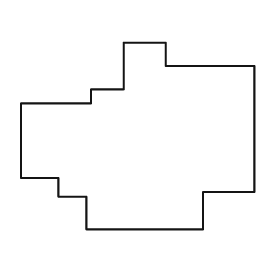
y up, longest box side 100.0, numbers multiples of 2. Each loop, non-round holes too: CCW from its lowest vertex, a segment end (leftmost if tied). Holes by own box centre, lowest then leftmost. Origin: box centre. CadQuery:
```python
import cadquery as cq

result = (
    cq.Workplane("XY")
    .moveTo(-22.0, -40.0)
    .lineTo(28.0, -40.0)
    .lineTo(28.0, -24.0)
    .lineTo(50.0, -24.0)
    .lineTo(50.0, 30.0)
    .lineTo(12.0, 30.0)
    .lineTo(12.0, 40.0)
    .lineTo(-6.0, 40.0)
    .lineTo(-6.0, 20.0)
    .lineTo(-20.0, 20.0)
    .lineTo(-20.0, 14.0)
    .lineTo(-50.0, 14.0)
    .lineTo(-50.0, -18.0)
    .lineTo(-34.0, -18.0)
    .lineTo(-34.0, -26.0)
    .lineTo(-22.0, -26.0)
    .close()
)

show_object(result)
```